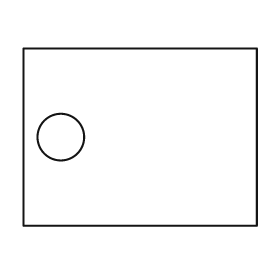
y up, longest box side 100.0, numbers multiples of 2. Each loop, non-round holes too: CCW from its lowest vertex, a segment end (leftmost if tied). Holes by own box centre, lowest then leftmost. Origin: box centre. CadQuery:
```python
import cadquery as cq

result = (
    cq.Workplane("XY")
    .moveTo(-50.0, -38.0)
    .lineTo(50.0, -38.0)
    .lineTo(50.0, 38.0)
    .lineTo(-50.0, 38.0)
    .close()
    .moveTo(-34.0, 0.0)
    .circle(10.0)
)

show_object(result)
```